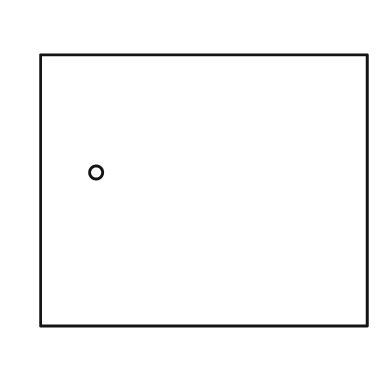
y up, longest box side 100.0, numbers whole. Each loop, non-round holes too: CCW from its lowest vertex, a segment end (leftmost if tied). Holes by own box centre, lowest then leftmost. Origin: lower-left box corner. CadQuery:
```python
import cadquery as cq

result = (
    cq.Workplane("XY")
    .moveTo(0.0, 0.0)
    .lineTo(100.0, 0.0)
    .lineTo(100.0, 83.0)
    .lineTo(0.0, 83.0)
    .close()
    .moveTo(17.0, 47.0)
    .circle(2.0)
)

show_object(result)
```